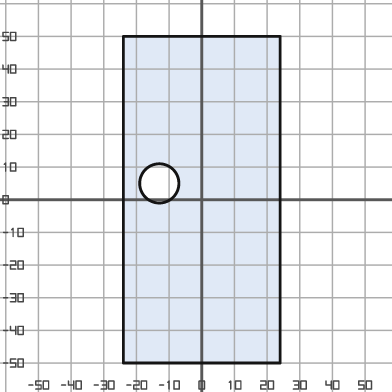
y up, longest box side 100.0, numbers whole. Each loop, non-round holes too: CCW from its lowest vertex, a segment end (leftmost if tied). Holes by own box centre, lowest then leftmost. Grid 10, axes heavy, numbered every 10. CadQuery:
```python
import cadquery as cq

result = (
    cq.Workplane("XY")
    .moveTo(-24.0, -50.0)
    .lineTo(24.0, -50.0)
    .lineTo(24.0, 50.0)
    .lineTo(-24.0, 50.0)
    .close()
    .moveTo(-13.0, 5.0)
    .circle(6.0)
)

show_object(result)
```